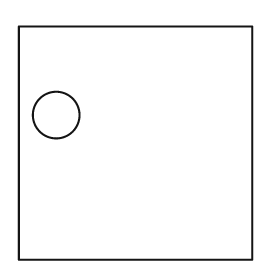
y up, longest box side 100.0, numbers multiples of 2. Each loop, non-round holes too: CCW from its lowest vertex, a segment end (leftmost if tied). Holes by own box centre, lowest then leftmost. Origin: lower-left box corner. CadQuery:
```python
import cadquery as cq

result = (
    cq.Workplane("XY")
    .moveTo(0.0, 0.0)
    .lineTo(100.0, 0.0)
    .lineTo(100.0, 100.0)
    .lineTo(0.0, 100.0)
    .close()
    .moveTo(16.0, 62.0)
    .circle(10.0)
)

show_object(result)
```